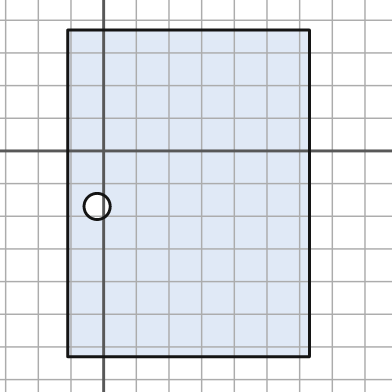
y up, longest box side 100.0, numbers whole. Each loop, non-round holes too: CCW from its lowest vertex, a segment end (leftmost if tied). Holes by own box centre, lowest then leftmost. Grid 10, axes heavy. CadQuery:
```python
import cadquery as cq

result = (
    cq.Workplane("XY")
    .moveTo(-11.0, -63.0)
    .lineTo(63.0, -63.0)
    .lineTo(63.0, 37.0)
    .lineTo(-11.0, 37.0)
    .close()
    .moveTo(-2.0, -17.0)
    .circle(4.0)
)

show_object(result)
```